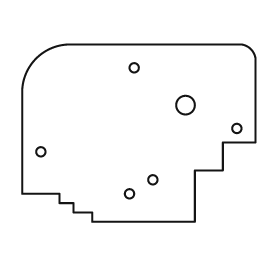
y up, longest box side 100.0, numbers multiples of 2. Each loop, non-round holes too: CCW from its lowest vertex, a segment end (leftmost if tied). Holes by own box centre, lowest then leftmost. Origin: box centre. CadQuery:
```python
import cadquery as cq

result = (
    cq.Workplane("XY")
    .moveTo(-20.0, -38.0)
    .lineTo(24.0, -38.0)
    .lineTo(24.0, -16.0)
    .lineTo(36.0, -16.0)
    .lineTo(36.0, -4.0)
    .lineTo(50.0, -4.0)
    .lineTo(50.0, 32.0)
    .threePointArc((48.0, 36.0), (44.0, 38.0))
    .lineTo(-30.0, 38.0)
    .threePointArc((-44.0, 32.0), (-50.0, 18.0))
    .lineTo(-50.0, -26.0)
    .lineTo(-34.0, -26.0)
    .lineTo(-34.0, -30.0)
    .lineTo(-28.0, -30.0)
    .lineTo(-28.0, -34.0)
    .lineTo(-20.0, -34.0)
    .close()
    .moveTo(-4.0, -26.0)
    .circle(2.0)
    .moveTo(6.0, -20.0)
    .circle(2.0)
    .moveTo(-42.0, -8.0)
    .circle(2.0)
    .moveTo(42.0, 2.0)
    .circle(2.0)
    .moveTo(20.0, 12.0)
    .circle(4.0)
    .moveTo(-2.0, 28.0)
    .circle(2.0)
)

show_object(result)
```